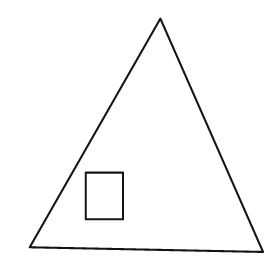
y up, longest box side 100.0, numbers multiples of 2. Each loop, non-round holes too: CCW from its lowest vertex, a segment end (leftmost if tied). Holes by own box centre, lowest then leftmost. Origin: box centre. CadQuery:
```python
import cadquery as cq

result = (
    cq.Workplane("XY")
    .moveTo(50.0, -50.0)
    .lineTo(6.0, 50.0)
    .lineTo(-50.0, -48.0)
    .close()
    .moveTo(-26.0, -36.0)
    .lineTo(-10.0, -36.0)
    .lineTo(-10.0, -16.0)
    .lineTo(-26.0, -16.0)
    .close()
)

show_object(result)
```